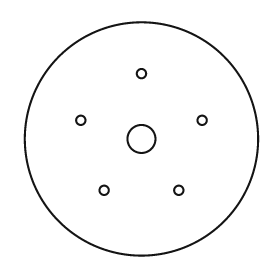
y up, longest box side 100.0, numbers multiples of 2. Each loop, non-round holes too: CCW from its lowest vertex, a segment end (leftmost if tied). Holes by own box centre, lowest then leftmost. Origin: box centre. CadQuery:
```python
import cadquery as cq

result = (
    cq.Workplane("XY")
    .moveTo(0.0, 0.0)
    .circle(50.0)
    .moveTo(-16.0, -22.0)
    .circle(2.0)
    .moveTo(16.0, -22.0)
    .circle(2.0)
    .moveTo(0.0, 0.0)
    .circle(6.0)
    .moveTo(-26.0, 8.0)
    .circle(2.0)
    .moveTo(26.0, 8.0)
    .circle(2.0)
    .moveTo(0.0, 28.0)
    .circle(2.0)
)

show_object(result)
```